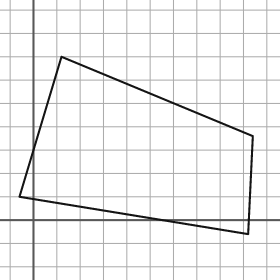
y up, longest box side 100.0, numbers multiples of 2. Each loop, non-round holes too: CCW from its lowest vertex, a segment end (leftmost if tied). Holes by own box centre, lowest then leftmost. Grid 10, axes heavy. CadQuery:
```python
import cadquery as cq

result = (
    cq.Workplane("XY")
    .moveTo(92.0, -6.0)
    .lineTo(94.0, 36.0)
    .lineTo(12.0, 70.0)
    .lineTo(-6.0, 10.0)
    .close()
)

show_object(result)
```